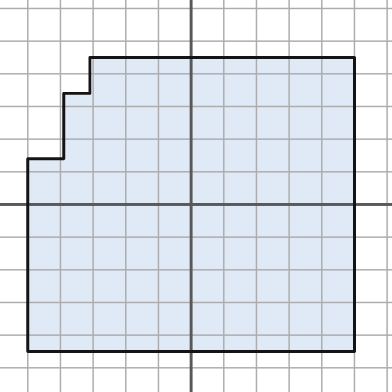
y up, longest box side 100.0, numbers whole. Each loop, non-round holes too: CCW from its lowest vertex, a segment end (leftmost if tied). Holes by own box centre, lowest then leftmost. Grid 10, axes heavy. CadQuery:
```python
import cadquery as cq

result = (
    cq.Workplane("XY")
    .moveTo(-50.0, -45.0)
    .lineTo(50.0, -45.0)
    .lineTo(50.0, 45.0)
    .lineTo(-31.0, 45.0)
    .lineTo(-31.0, 34.0)
    .lineTo(-39.0, 34.0)
    .lineTo(-39.0, 14.0)
    .lineTo(-50.0, 14.0)
    .close()
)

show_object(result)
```